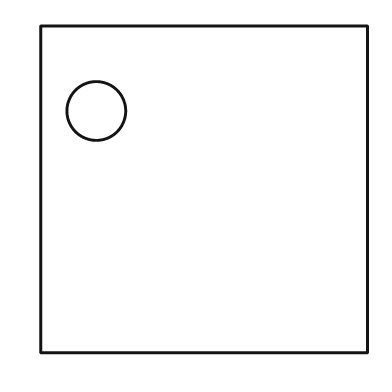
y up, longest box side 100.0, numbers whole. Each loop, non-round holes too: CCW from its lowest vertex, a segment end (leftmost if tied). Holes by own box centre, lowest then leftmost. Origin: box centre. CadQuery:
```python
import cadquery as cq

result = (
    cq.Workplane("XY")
    .moveTo(-50.0, -50.0)
    .lineTo(50.0, -50.0)
    .lineTo(50.0, 50.0)
    .lineTo(-50.0, 50.0)
    .close()
    .moveTo(-33.0, 24.0)
    .circle(9.0)
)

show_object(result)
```